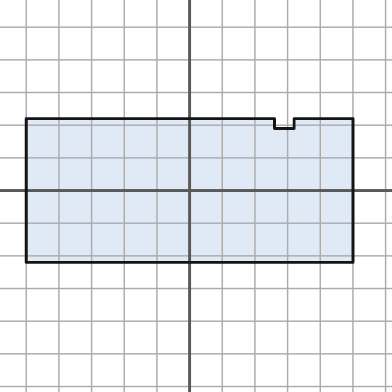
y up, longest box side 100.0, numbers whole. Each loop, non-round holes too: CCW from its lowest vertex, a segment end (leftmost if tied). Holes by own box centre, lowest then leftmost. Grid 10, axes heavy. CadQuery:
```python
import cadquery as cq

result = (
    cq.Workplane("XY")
    .moveTo(-50.0, -22.0)
    .lineTo(50.0, -22.0)
    .lineTo(50.0, 22.0)
    .lineTo(32.0, 22.0)
    .lineTo(32.0, 19.0)
    .lineTo(26.0, 19.0)
    .lineTo(26.0, 22.0)
    .lineTo(-50.0, 22.0)
    .close()
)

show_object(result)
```